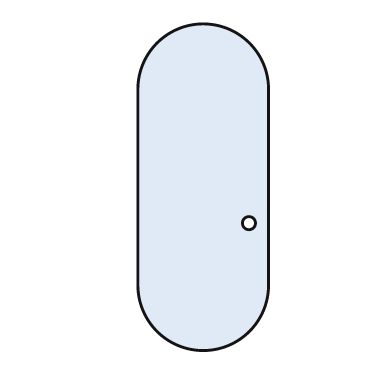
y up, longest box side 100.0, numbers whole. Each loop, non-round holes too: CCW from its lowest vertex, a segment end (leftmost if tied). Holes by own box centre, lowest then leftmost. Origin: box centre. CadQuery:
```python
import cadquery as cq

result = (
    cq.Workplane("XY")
    .moveTo(-20.0, -30.0)
    .threePointArc((0.0, -50.0), (20.0, -30.0))
    .lineTo(20.0, 30.0)
    .threePointArc((0.0, 50.0), (-20.0, 30.0))
    .close()
    .moveTo(14.0, -11.0)
    .circle(2.0)
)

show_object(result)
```